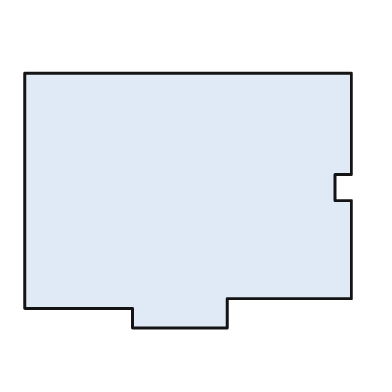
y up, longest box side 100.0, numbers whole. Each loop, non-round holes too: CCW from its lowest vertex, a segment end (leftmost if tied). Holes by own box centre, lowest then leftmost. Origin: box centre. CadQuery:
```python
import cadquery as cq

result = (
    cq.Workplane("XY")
    .moveTo(-17.0, -39.0)
    .lineTo(12.0, -39.0)
    .lineTo(12.0, -30.0)
    .lineTo(50.0, -30.0)
    .lineTo(50.0, 0.0)
    .lineTo(45.0, 0.0)
    .lineTo(45.0, 8.0)
    .lineTo(50.0, 8.0)
    .lineTo(50.0, 39.0)
    .lineTo(-50.0, 39.0)
    .lineTo(-50.0, -33.0)
    .lineTo(-17.0, -33.0)
    .close()
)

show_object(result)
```